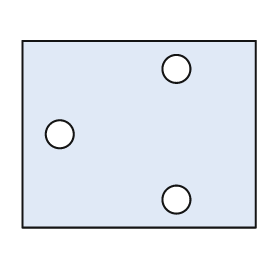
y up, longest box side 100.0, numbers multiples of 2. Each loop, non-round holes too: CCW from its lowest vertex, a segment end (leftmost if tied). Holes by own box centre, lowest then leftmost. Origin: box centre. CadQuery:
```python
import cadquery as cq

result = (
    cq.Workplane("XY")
    .moveTo(-50.0, -40.0)
    .lineTo(50.0, -40.0)
    .lineTo(50.0, 40.0)
    .lineTo(-50.0, 40.0)
    .close()
    .moveTo(16.0, -28.0)
    .circle(6.0)
    .moveTo(-34.0, 0.0)
    .circle(6.0)
    .moveTo(16.0, 28.0)
    .circle(6.0)
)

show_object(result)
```